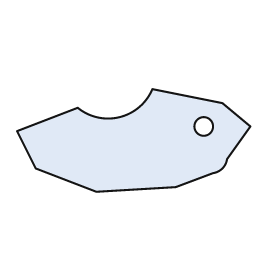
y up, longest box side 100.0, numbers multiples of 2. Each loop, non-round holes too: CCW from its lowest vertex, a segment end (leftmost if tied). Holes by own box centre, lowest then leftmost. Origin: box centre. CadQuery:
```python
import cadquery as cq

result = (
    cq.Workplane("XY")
    .moveTo(-16.0, -22.0)
    .lineTo(18.0, -20.0)
    .lineTo(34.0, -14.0)
    .threePointArc((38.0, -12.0), (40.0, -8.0))
    .lineTo(50.0, 6.0)
    .lineTo(38.0, 16.0)
    .lineTo(8.0, 22.0)
    .threePointArc((-6.0, 10.0), (-24.0, 14.0))
    .lineTo(-50.0, 4.0)
    .lineTo(-42.0, -12.0)
    .close()
    .moveTo(30.0, 6.0)
    .circle(4.0)
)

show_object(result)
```